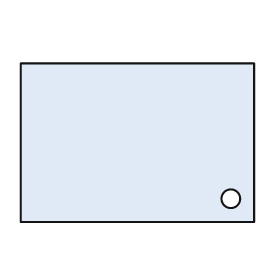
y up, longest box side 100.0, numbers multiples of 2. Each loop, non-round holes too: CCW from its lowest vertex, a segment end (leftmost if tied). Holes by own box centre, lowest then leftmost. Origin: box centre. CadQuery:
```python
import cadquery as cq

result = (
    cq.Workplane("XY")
    .moveTo(-50.0, -34.0)
    .lineTo(50.0, -34.0)
    .lineTo(50.0, 34.0)
    .lineTo(-50.0, 34.0)
    .close()
    .moveTo(40.0, -24.0)
    .circle(4.0)
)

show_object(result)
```